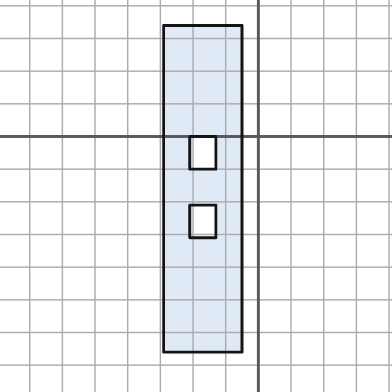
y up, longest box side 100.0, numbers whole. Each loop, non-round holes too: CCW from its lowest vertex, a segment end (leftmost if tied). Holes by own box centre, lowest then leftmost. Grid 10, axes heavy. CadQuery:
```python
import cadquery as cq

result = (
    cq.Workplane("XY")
    .moveTo(-29.0, -66.0)
    .lineTo(-5.0, -66.0)
    .lineTo(-5.0, 34.0)
    .lineTo(-29.0, 34.0)
    .close()
    .moveTo(-21.0, -31.0)
    .lineTo(-13.0, -31.0)
    .lineTo(-13.0, -21.0)
    .lineTo(-21.0, -21.0)
    .close()
    .moveTo(-21.0, -10.0)
    .lineTo(-13.0, -10.0)
    .lineTo(-13.0, 0.0)
    .lineTo(-21.0, 0.0)
    .close()
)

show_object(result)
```